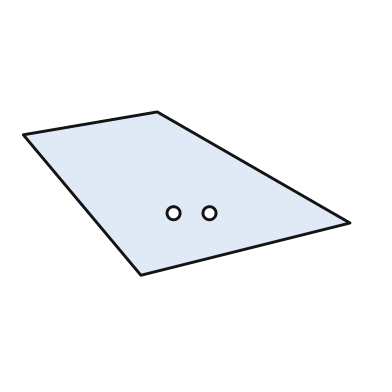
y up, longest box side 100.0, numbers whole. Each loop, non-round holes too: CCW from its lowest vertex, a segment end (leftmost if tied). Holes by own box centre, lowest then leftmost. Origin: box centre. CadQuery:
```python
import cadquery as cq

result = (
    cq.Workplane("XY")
    .moveTo(-14.0, -25.0)
    .lineTo(50.0, -9.0)
    .lineTo(-9.0, 25.0)
    .lineTo(-50.0, 18.0)
    .close()
    .moveTo(-4.0, -6.0)
    .circle(2.0)
    .moveTo(7.0, -6.0)
    .circle(2.0)
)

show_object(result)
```